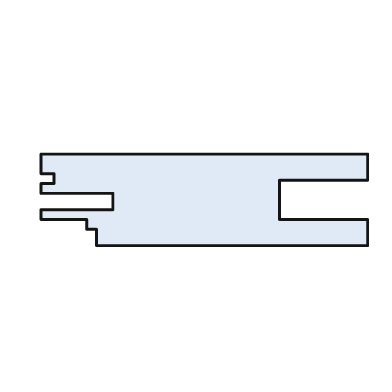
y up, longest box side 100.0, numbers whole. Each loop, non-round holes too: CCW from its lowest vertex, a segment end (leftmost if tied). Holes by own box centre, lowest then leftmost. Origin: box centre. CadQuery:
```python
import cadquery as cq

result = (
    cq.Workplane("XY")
    .moveTo(-33.0, -14.0)
    .lineTo(50.0, -14.0)
    .lineTo(50.0, -6.0)
    .lineTo(23.0, -6.0)
    .lineTo(23.0, 6.0)
    .lineTo(50.0, 6.0)
    .lineTo(50.0, 14.0)
    .lineTo(-50.0, 14.0)
    .lineTo(-50.0, 8.0)
    .lineTo(-46.0, 8.0)
    .lineTo(-46.0, 5.0)
    .lineTo(-50.0, 5.0)
    .lineTo(-50.0, 2.0)
    .lineTo(-28.0, 2.0)
    .lineTo(-28.0, -3.0)
    .lineTo(-50.0, -3.0)
    .lineTo(-50.0, -6.0)
    .lineTo(-36.0, -6.0)
    .lineTo(-36.0, -9.0)
    .lineTo(-33.0, -9.0)
    .close()
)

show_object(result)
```